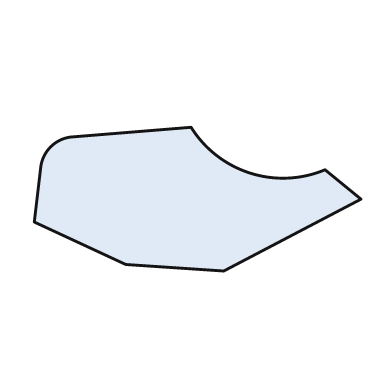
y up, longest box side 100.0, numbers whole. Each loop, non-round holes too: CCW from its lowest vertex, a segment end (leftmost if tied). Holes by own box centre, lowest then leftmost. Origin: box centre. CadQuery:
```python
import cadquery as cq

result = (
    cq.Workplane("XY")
    .moveTo(8.0, -22.0)
    .lineTo(50.0, 0.0)
    .lineTo(39.0, 9.0)
    .threePointArc((16.0, 8.0), (-2.0, 22.0))
    .lineTo(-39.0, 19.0)
    .threePointArc((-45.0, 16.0), (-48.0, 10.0))
    .lineTo(-50.0, -7.0)
    .lineTo(-22.0, -20.0)
    .close()
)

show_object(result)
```